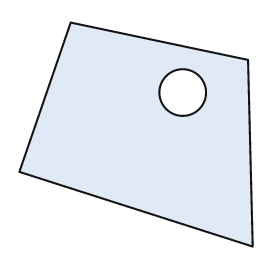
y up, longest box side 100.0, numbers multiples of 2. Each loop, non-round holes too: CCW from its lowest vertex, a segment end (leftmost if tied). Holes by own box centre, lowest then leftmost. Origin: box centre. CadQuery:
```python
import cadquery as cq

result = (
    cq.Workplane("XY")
    .moveTo(50.0, -48.0)
    .lineTo(48.0, 32.0)
    .lineTo(-28.0, 48.0)
    .lineTo(-50.0, -16.0)
    .close()
    .moveTo(20.0, 18.0)
    .circle(10.0)
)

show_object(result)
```